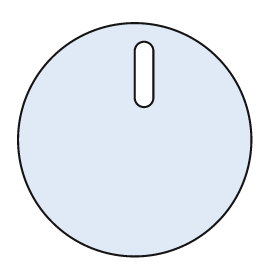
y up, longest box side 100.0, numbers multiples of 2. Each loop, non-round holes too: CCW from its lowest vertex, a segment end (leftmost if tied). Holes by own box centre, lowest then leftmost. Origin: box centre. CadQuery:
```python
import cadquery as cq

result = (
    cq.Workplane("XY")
    .moveTo(0.0, 0.0)
    .circle(50.0)
    .moveTo(0.0, 18.0)
    .threePointArc((4.0, 14.0), (8.0, 18.0))
    .lineTo(8.0, 38.0)
    .threePointArc((4.0, 42.0), (0.0, 38.0))
    .close()
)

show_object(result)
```